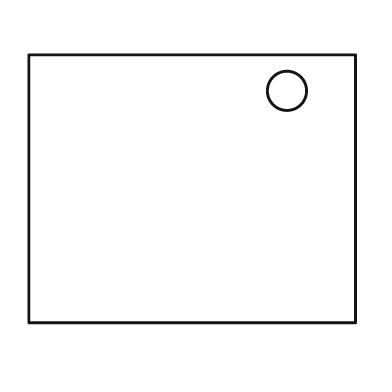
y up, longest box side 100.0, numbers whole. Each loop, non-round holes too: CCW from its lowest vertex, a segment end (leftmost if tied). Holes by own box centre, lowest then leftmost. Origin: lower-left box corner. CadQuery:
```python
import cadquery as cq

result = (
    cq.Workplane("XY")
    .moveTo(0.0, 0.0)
    .lineTo(100.0, 0.0)
    .lineTo(100.0, 82.0)
    .lineTo(0.0, 82.0)
    .close()
    .moveTo(79.0, 71.0)
    .circle(6.0)
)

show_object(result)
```